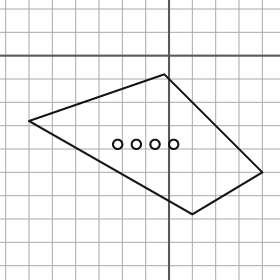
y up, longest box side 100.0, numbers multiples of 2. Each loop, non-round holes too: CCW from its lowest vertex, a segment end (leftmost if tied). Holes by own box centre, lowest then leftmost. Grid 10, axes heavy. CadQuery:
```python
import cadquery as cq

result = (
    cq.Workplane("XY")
    .moveTo(10.0, -68.0)
    .lineTo(40.0, -50.0)
    .lineTo(-2.0, -8.0)
    .lineTo(-60.0, -28.0)
    .close()
    .moveTo(-22.0, -38.0)
    .circle(2.0)
    .moveTo(-14.0, -38.0)
    .circle(2.0)
    .moveTo(-6.0, -38.0)
    .circle(2.0)
    .moveTo(2.0, -38.0)
    .circle(2.0)
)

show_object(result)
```